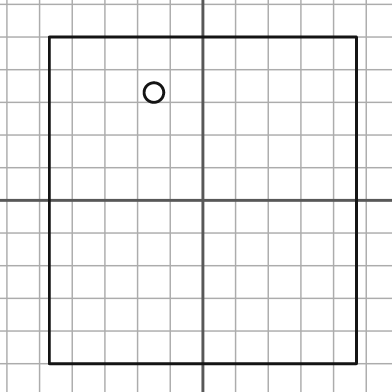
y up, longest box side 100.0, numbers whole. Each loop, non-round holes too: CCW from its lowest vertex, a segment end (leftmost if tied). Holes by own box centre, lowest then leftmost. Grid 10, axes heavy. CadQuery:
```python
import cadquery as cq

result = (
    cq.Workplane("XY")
    .moveTo(-47.0, -50.0)
    .lineTo(47.0, -50.0)
    .lineTo(47.0, 50.0)
    .lineTo(-47.0, 50.0)
    .close()
    .moveTo(-15.0, 33.0)
    .circle(3.0)
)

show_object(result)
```